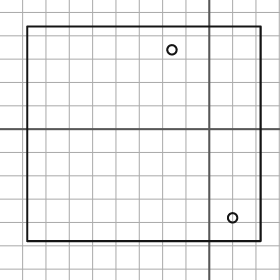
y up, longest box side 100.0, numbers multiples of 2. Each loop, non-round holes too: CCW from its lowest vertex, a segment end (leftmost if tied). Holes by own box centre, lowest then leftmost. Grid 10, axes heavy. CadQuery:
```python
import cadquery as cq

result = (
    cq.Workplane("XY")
    .moveTo(-78.0, -48.0)
    .lineTo(22.0, -48.0)
    .lineTo(22.0, 44.0)
    .lineTo(-78.0, 44.0)
    .close()
    .moveTo(10.0, -38.0)
    .circle(2.0)
    .moveTo(-16.0, 34.0)
    .circle(2.0)
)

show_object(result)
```